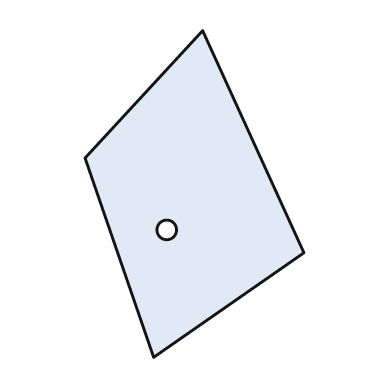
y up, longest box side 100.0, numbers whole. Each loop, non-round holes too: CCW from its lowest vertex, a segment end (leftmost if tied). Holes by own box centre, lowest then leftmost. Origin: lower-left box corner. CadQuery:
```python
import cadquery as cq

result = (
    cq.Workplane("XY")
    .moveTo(21.0, 0.0)
    .lineTo(67.0, 32.0)
    .lineTo(36.0, 100.0)
    .lineTo(0.0, 61.0)
    .close()
    .moveTo(25.0, 39.0)
    .circle(3.0)
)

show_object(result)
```